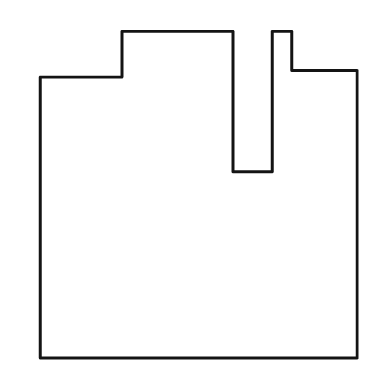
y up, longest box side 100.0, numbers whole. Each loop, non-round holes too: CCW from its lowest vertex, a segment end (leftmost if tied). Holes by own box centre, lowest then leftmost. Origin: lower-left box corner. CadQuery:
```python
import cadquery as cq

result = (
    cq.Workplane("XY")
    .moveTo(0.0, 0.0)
    .lineTo(97.0, 0.0)
    .lineTo(97.0, 88.0)
    .lineTo(77.0, 88.0)
    .lineTo(77.0, 100.0)
    .lineTo(71.0, 100.0)
    .lineTo(71.0, 57.0)
    .lineTo(59.0, 57.0)
    .lineTo(59.0, 100.0)
    .lineTo(25.0, 100.0)
    .lineTo(25.0, 86.0)
    .lineTo(0.0, 86.0)
    .close()
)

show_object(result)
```